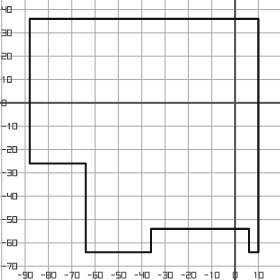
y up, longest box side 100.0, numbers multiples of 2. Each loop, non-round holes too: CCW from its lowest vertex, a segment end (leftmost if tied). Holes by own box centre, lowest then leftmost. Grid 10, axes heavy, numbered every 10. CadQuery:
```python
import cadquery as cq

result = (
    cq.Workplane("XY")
    .moveTo(-64.0, -64.0)
    .lineTo(-36.0, -64.0)
    .lineTo(-36.0, -54.0)
    .lineTo(6.0, -54.0)
    .lineTo(6.0, -64.0)
    .lineTo(10.0, -64.0)
    .lineTo(10.0, 36.0)
    .lineTo(-88.0, 36.0)
    .lineTo(-88.0, -26.0)
    .lineTo(-64.0, -26.0)
    .close()
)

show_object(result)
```